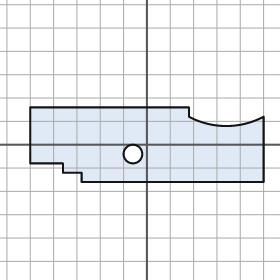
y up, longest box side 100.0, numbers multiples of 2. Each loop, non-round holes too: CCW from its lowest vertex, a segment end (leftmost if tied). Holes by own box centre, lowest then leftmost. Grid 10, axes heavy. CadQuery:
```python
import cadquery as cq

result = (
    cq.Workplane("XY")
    .moveTo(-28.0, -16.0)
    .lineTo(50.0, -16.0)
    .lineTo(50.0, 12.0)
    .threePointArc((34.0, 8.0), (18.0, 12.0))
    .lineTo(18.0, 16.0)
    .lineTo(-50.0, 16.0)
    .lineTo(-50.0, -8.0)
    .lineTo(-36.0, -8.0)
    .lineTo(-36.0, -12.0)
    .lineTo(-28.0, -12.0)
    .close()
    .moveTo(-6.0, -4.0)
    .circle(4.0)
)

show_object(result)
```